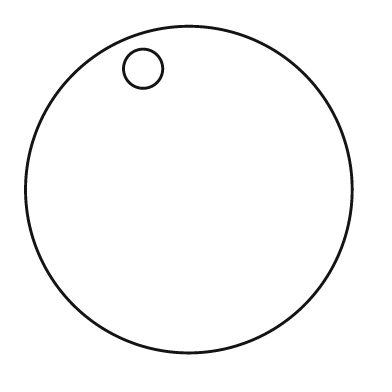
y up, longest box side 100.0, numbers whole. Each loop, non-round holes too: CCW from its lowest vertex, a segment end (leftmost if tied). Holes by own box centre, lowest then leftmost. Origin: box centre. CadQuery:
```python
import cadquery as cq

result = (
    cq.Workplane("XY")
    .moveTo(0.0, 0.0)
    .circle(50.0)
    .moveTo(-14.0, 37.0)
    .circle(6.0)
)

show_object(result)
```